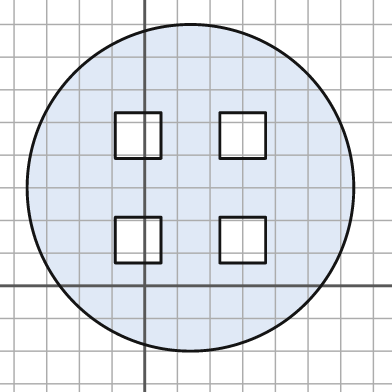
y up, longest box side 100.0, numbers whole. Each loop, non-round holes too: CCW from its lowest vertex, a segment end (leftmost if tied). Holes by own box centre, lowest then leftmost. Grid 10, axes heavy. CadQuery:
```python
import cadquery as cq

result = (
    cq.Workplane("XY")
    .moveTo(14.0, 30.0)
    .circle(50.0)
    .moveTo(-9.0, 7.0)
    .lineTo(5.0, 7.0)
    .lineTo(5.0, 21.0)
    .lineTo(-9.0, 21.0)
    .close()
    .moveTo(23.0, 7.0)
    .lineTo(37.0, 7.0)
    .lineTo(37.0, 21.0)
    .lineTo(23.0, 21.0)
    .close()
    .moveTo(-9.0, 39.0)
    .lineTo(5.0, 39.0)
    .lineTo(5.0, 53.0)
    .lineTo(-9.0, 53.0)
    .close()
    .moveTo(23.0, 39.0)
    .lineTo(37.0, 39.0)
    .lineTo(37.0, 53.0)
    .lineTo(23.0, 53.0)
    .close()
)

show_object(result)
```